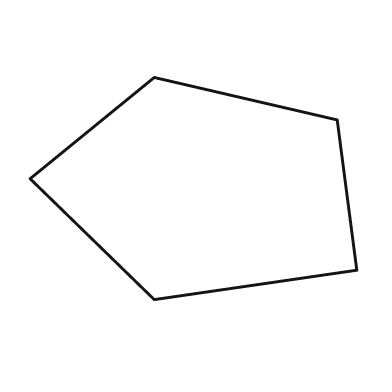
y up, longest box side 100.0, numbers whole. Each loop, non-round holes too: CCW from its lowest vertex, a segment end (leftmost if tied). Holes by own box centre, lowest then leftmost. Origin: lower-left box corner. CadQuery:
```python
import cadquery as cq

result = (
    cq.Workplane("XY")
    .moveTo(38.0, 0.0)
    .lineTo(100.0, 9.0)
    .lineTo(94.0, 55.0)
    .lineTo(38.0, 68.0)
    .lineTo(0.0, 37.0)
    .close()
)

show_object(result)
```